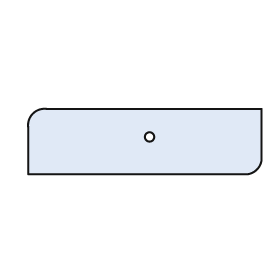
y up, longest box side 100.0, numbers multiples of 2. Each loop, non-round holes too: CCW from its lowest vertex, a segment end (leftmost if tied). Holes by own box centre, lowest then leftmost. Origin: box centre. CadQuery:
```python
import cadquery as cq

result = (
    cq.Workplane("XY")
    .moveTo(-50.0, -14.0)
    .lineTo(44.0, -14.0)
    .threePointArc((48.0, -12.0), (50.0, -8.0))
    .lineTo(50.0, 14.0)
    .lineTo(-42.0, 14.0)
    .threePointArc((-48.0, 12.0), (-50.0, 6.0))
    .close()
    .moveTo(2.0, 2.0)
    .circle(2.0)
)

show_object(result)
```